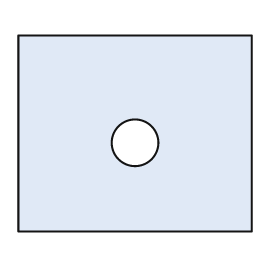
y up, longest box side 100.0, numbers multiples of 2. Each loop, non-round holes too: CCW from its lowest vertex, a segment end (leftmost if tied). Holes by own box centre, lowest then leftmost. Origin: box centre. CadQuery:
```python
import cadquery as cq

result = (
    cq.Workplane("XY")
    .moveTo(-50.0, -42.0)
    .lineTo(50.0, -42.0)
    .lineTo(50.0, 42.0)
    .lineTo(-50.0, 42.0)
    .close()
    .moveTo(0.0, -4.0)
    .circle(10.0)
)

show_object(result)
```